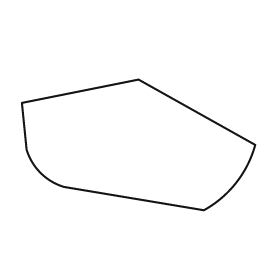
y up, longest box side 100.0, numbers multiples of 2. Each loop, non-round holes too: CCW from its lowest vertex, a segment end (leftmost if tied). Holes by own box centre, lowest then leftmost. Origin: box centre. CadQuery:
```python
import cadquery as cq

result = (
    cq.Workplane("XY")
    .moveTo(28.0, -28.0)
    .threePointArc((42.0, -16.0), (50.0, 0.0))
    .lineTo(0.0, 28.0)
    .lineTo(-50.0, 18.0)
    .lineTo(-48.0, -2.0)
    .threePointArc((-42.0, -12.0), (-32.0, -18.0))
    .close()
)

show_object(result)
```